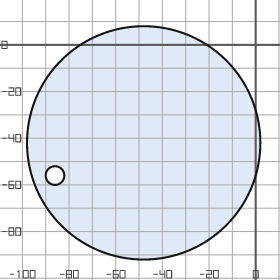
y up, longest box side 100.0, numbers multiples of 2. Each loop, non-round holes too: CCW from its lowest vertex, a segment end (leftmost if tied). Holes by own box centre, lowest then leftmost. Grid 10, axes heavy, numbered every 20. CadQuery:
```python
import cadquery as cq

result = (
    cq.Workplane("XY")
    .moveTo(-48.0, -42.0)
    .circle(50.0)
    .moveTo(-86.0, -56.0)
    .circle(4.0)
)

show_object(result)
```